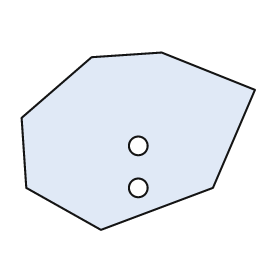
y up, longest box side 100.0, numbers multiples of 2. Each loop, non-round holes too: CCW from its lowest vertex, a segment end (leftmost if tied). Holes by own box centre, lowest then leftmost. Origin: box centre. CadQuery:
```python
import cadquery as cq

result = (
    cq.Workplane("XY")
    .moveTo(-16.0, -38.0)
    .lineTo(32.0, -20.0)
    .lineTo(50.0, 22.0)
    .lineTo(10.0, 38.0)
    .lineTo(-20.0, 36.0)
    .lineTo(-50.0, 10.0)
    .lineTo(-48.0, -20.0)
    .close()
    .moveTo(0.0, -20.0)
    .circle(4.0)
    .moveTo(0.0, -2.0)
    .circle(4.0)
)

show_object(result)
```